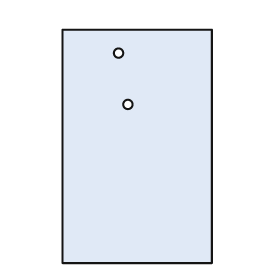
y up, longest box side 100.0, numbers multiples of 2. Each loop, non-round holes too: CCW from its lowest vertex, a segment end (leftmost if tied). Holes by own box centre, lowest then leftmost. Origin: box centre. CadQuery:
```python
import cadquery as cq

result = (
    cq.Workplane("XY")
    .moveTo(-32.0, -50.0)
    .lineTo(32.0, -50.0)
    .lineTo(32.0, 50.0)
    .lineTo(-32.0, 50.0)
    .close()
    .moveTo(-4.0, 18.0)
    .circle(2.0)
    .moveTo(-8.0, 40.0)
    .circle(2.0)
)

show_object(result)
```